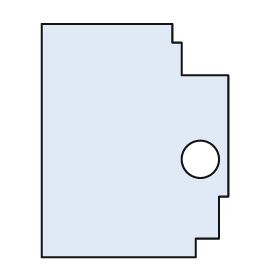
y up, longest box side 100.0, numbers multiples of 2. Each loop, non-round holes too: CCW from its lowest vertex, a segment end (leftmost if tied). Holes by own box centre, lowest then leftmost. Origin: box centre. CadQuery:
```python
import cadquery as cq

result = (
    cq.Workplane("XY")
    .moveTo(-40.0, -50.0)
    .lineTo(26.0, -50.0)
    .lineTo(26.0, -42.0)
    .lineTo(36.0, -42.0)
    .lineTo(36.0, -24.0)
    .lineTo(40.0, -24.0)
    .lineTo(40.0, 28.0)
    .lineTo(20.0, 28.0)
    .lineTo(20.0, 42.0)
    .lineTo(16.0, 42.0)
    .lineTo(16.0, 50.0)
    .lineTo(-40.0, 50.0)
    .close()
    .moveTo(28.0, -8.0)
    .circle(8.0)
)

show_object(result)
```